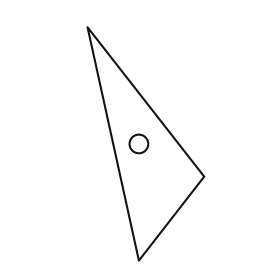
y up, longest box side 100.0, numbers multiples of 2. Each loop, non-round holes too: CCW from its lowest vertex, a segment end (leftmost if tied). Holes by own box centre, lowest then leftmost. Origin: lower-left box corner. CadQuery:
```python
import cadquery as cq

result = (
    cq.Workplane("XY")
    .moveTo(22.0, 0.0)
    .lineTo(50.0, 36.0)
    .lineTo(0.0, 100.0)
    .close()
    .moveTo(22.0, 50.0)
    .circle(4.0)
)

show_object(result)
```